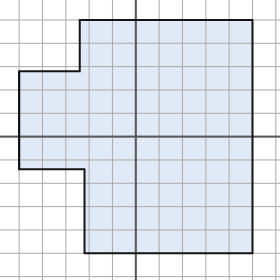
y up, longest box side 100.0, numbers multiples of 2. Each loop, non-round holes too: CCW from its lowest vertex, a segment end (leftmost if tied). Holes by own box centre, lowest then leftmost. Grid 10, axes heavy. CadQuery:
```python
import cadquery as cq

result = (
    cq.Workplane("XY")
    .moveTo(-22.0, -50.0)
    .lineTo(50.0, -50.0)
    .lineTo(50.0, 50.0)
    .lineTo(-24.0, 50.0)
    .lineTo(-24.0, 28.0)
    .lineTo(-50.0, 28.0)
    .lineTo(-50.0, -14.0)
    .lineTo(-22.0, -14.0)
    .close()
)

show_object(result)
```